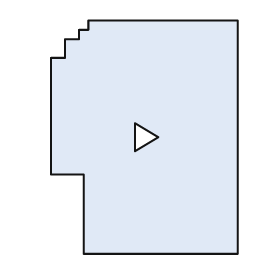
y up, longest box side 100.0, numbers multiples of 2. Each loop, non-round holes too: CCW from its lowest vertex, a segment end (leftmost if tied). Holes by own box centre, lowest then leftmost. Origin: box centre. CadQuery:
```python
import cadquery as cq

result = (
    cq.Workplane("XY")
    .moveTo(-26.0, -50.0)
    .lineTo(40.0, -50.0)
    .lineTo(40.0, 50.0)
    .lineTo(-24.0, 50.0)
    .lineTo(-24.0, 46.0)
    .lineTo(-28.0, 46.0)
    .lineTo(-28.0, 42.0)
    .lineTo(-34.0, 42.0)
    .lineTo(-34.0, 34.0)
    .lineTo(-40.0, 34.0)
    .lineTo(-40.0, -16.0)
    .lineTo(-26.0, -16.0)
    .close()
    .moveTo(-4.0, -6.0)
    .lineTo(6.0, 0.0)
    .lineTo(-4.0, 6.0)
    .close()
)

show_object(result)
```